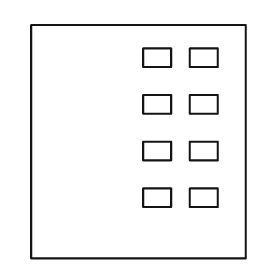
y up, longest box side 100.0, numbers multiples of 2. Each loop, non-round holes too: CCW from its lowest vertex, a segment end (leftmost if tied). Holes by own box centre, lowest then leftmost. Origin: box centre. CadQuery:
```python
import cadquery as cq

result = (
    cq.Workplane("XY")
    .moveTo(-46.0, -50.0)
    .lineTo(46.0, -50.0)
    .lineTo(46.0, 50.0)
    .lineTo(-46.0, 50.0)
    .close()
    .moveTo(2.0, -28.0)
    .lineTo(14.0, -28.0)
    .lineTo(14.0, -20.0)
    .lineTo(2.0, -20.0)
    .close()
    .moveTo(22.0, -28.0)
    .lineTo(34.0, -28.0)
    .lineTo(34.0, -20.0)
    .lineTo(22.0, -20.0)
    .close()
    .moveTo(2.0, -8.0)
    .lineTo(14.0, -8.0)
    .lineTo(14.0, 0.0)
    .lineTo(2.0, 0.0)
    .close()
    .moveTo(22.0, -8.0)
    .lineTo(34.0, -8.0)
    .lineTo(34.0, 0.0)
    .lineTo(22.0, 0.0)
    .close()
    .moveTo(2.0, 12.0)
    .lineTo(14.0, 12.0)
    .lineTo(14.0, 20.0)
    .lineTo(2.0, 20.0)
    .close()
    .moveTo(22.0, 12.0)
    .lineTo(34.0, 12.0)
    .lineTo(34.0, 20.0)
    .lineTo(22.0, 20.0)
    .close()
    .moveTo(2.0, 32.0)
    .lineTo(14.0, 32.0)
    .lineTo(14.0, 40.0)
    .lineTo(2.0, 40.0)
    .close()
    .moveTo(22.0, 32.0)
    .lineTo(34.0, 32.0)
    .lineTo(34.0, 40.0)
    .lineTo(22.0, 40.0)
    .close()
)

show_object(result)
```